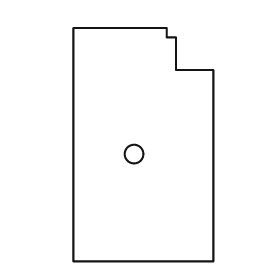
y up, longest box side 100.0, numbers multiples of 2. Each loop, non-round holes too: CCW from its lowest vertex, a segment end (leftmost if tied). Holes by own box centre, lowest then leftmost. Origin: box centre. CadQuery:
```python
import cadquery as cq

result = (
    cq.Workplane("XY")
    .moveTo(-30.0, -50.0)
    .lineTo(30.0, -50.0)
    .lineTo(30.0, 32.0)
    .lineTo(14.0, 32.0)
    .lineTo(14.0, 46.0)
    .lineTo(10.0, 46.0)
    .lineTo(10.0, 50.0)
    .lineTo(-30.0, 50.0)
    .close()
    .moveTo(-4.0, -4.0)
    .circle(4.0)
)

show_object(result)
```